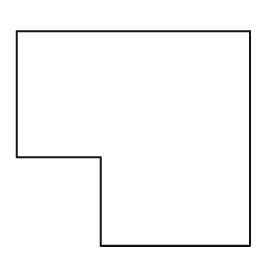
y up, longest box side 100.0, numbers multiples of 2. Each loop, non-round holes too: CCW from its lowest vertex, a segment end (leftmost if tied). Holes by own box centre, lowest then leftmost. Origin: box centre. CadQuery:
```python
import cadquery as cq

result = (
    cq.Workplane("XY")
    .moveTo(-14.0, -46.0)
    .lineTo(50.0, -46.0)
    .lineTo(50.0, 46.0)
    .lineTo(-50.0, 46.0)
    .lineTo(-50.0, -8.0)
    .lineTo(-14.0, -8.0)
    .close()
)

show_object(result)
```